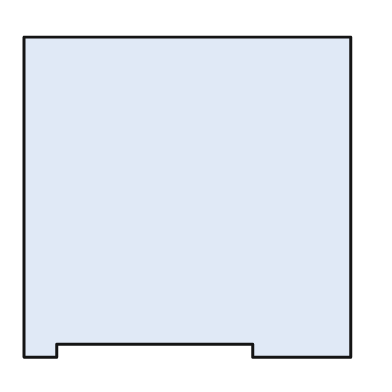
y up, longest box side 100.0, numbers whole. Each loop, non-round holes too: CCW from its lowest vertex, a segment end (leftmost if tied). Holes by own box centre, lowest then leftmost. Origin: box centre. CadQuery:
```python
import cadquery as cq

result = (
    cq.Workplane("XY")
    .moveTo(-50.0, -49.0)
    .lineTo(-40.0, -49.0)
    .lineTo(-40.0, -45.0)
    .lineTo(20.0, -45.0)
    .lineTo(20.0, -49.0)
    .lineTo(50.0, -49.0)
    .lineTo(50.0, 49.0)
    .lineTo(-50.0, 49.0)
    .close()
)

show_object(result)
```